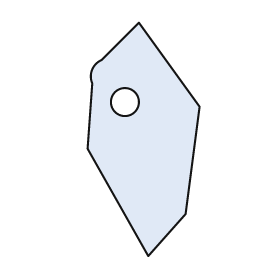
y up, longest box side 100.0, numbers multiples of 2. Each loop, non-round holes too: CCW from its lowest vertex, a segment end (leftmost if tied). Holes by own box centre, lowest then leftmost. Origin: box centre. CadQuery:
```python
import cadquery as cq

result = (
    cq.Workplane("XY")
    .moveTo(2.0, -50.0)
    .lineTo(18.0, -32.0)
    .lineTo(24.0, 14.0)
    .lineTo(-2.0, 50.0)
    .lineTo(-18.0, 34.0)
    .threePointArc((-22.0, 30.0), (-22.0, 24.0))
    .lineTo(-24.0, -4.0)
    .close()
    .moveTo(-8.0, 16.0)
    .circle(6.0)
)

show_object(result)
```